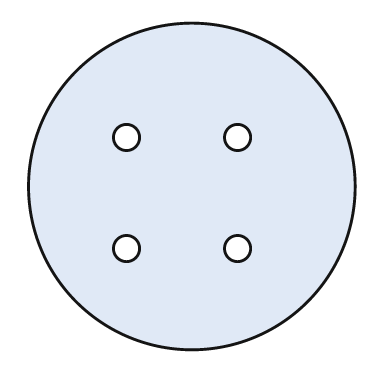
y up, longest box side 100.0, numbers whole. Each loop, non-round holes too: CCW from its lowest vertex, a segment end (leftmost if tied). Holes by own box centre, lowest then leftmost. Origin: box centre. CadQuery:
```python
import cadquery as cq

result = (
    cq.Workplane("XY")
    .moveTo(0.0, 0.0)
    .circle(50.0)
    .moveTo(-20.0, -19.0)
    .circle(4.0)
    .moveTo(14.0, -19.0)
    .circle(4.0)
    .moveTo(-20.0, 15.0)
    .circle(4.0)
    .moveTo(14.0, 15.0)
    .circle(4.0)
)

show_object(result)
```